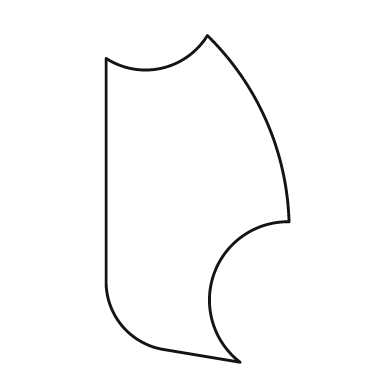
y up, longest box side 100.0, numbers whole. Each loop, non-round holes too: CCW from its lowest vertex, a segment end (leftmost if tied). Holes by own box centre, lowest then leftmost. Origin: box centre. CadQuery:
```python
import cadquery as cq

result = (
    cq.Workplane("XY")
    .moveTo(13.0, -50.0)
    .threePointArc((5.0, -23.0), (28.0, -7.0))
    .threePointArc((21.0, 24.0), (3.0, 50.0))
    .threePointArc((-11.0, 40.0), (-28.0, 43.0))
    .lineTo(-28.0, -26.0)
    .threePointArc((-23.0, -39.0), (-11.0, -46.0))
    .close()
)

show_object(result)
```